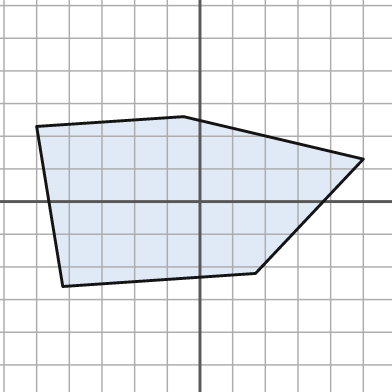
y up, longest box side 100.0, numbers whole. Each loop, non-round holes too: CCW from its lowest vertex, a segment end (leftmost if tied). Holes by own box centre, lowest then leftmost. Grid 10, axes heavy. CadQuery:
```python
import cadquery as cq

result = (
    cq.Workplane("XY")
    .moveTo(-42.0, -26.0)
    .lineTo(17.0, -22.0)
    .lineTo(50.0, 13.0)
    .lineTo(-5.0, 26.0)
    .lineTo(-50.0, 23.0)
    .close()
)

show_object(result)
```